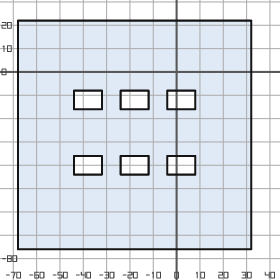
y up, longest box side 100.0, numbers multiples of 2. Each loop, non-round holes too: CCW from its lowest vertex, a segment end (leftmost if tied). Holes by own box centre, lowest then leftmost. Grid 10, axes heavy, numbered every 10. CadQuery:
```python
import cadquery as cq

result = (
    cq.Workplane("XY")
    .moveTo(-68.0, -76.0)
    .lineTo(32.0, -76.0)
    .lineTo(32.0, 22.0)
    .lineTo(-68.0, 22.0)
    .close()
    .moveTo(-44.0, -44.0)
    .lineTo(-32.0, -44.0)
    .lineTo(-32.0, -36.0)
    .lineTo(-44.0, -36.0)
    .close()
    .moveTo(-24.0, -44.0)
    .lineTo(-12.0, -44.0)
    .lineTo(-12.0, -36.0)
    .lineTo(-24.0, -36.0)
    .close()
    .moveTo(-4.0, -44.0)
    .lineTo(8.0, -44.0)
    .lineTo(8.0, -36.0)
    .lineTo(-4.0, -36.0)
    .close()
    .moveTo(-44.0, -16.0)
    .lineTo(-32.0, -16.0)
    .lineTo(-32.0, -8.0)
    .lineTo(-44.0, -8.0)
    .close()
    .moveTo(-24.0, -16.0)
    .lineTo(-12.0, -16.0)
    .lineTo(-12.0, -8.0)
    .lineTo(-24.0, -8.0)
    .close()
    .moveTo(-4.0, -16.0)
    .lineTo(8.0, -16.0)
    .lineTo(8.0, -8.0)
    .lineTo(-4.0, -8.0)
    .close()
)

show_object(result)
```